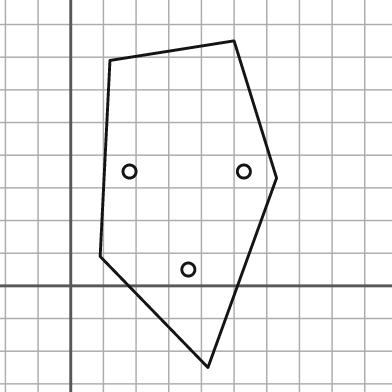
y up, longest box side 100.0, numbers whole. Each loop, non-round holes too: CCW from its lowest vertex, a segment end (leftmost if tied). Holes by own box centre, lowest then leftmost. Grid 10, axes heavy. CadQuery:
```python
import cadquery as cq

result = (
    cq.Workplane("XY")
    .moveTo(42.0, -25.0)
    .lineTo(63.0, 33.0)
    .lineTo(50.0, 75.0)
    .lineTo(12.0, 69.0)
    .lineTo(9.0, 9.0)
    .close()
    .moveTo(36.0, 5.0)
    .circle(2.0)
    .moveTo(18.0, 35.0)
    .circle(2.0)
    .moveTo(53.0, 35.0)
    .circle(2.0)
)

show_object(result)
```